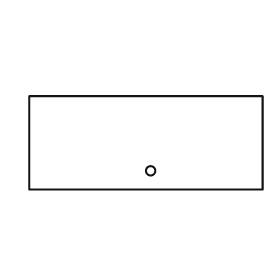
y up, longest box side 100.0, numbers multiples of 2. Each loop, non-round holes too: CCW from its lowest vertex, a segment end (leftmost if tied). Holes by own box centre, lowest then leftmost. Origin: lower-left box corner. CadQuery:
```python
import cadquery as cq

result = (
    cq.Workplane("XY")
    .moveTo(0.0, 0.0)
    .lineTo(100.0, 0.0)
    .lineTo(100.0, 40.0)
    .lineTo(0.0, 40.0)
    .close()
    .moveTo(52.0, 8.0)
    .circle(2.0)
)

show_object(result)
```